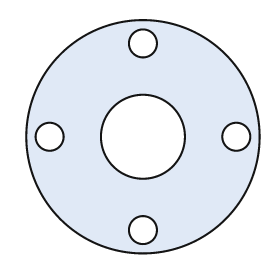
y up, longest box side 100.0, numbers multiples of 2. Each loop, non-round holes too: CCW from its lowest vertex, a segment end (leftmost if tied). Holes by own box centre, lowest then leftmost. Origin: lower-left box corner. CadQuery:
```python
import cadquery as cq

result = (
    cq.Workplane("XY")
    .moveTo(50.0, 50.0)
    .circle(50.0)
    .moveTo(50.0, 10.0)
    .circle(6.0)
    .moveTo(10.0, 50.0)
    .circle(6.0)
    .moveTo(50.0, 50.0)
    .circle(18.0)
    .moveTo(90.0, 50.0)
    .circle(6.0)
    .moveTo(50.0, 90.0)
    .circle(6.0)
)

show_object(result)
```